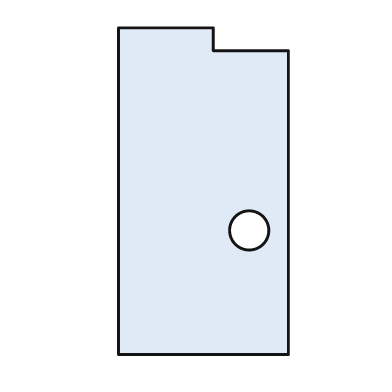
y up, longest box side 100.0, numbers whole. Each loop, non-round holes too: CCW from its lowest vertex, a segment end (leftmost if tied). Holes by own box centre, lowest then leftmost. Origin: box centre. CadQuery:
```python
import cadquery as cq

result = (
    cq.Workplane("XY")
    .moveTo(-26.0, -50.0)
    .lineTo(26.0, -50.0)
    .lineTo(26.0, 43.0)
    .lineTo(3.0, 43.0)
    .lineTo(3.0, 50.0)
    .lineTo(-26.0, 50.0)
    .close()
    .moveTo(14.0, -12.0)
    .circle(6.0)
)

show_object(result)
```